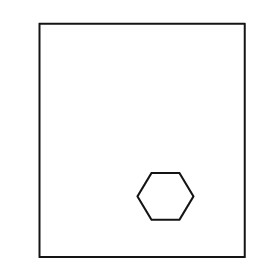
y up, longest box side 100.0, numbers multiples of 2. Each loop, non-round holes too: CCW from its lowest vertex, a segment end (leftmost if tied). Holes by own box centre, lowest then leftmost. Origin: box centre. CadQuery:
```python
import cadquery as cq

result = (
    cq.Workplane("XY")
    .moveTo(-44.0, -50.0)
    .lineTo(44.0, -50.0)
    .lineTo(44.0, 50.0)
    .lineTo(-44.0, 50.0)
    .close()
    .moveTo(4.0, -34.0)
    .lineTo(16.0, -34.0)
    .lineTo(22.0, -24.0)
    .lineTo(16.0, -14.0)
    .lineTo(4.0, -14.0)
    .lineTo(-2.0, -24.0)
    .close()
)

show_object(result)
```